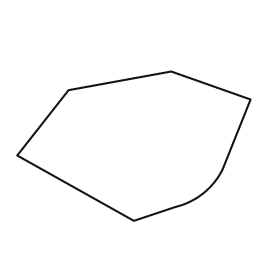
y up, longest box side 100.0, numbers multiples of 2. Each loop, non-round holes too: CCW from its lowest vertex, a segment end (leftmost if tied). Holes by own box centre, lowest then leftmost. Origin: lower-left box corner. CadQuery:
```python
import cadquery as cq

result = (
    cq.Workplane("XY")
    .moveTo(50.0, 0.0)
    .lineTo(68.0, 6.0)
    .threePointArc((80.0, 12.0), (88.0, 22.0))
    .lineTo(100.0, 52.0)
    .lineTo(66.0, 64.0)
    .lineTo(22.0, 56.0)
    .lineTo(0.0, 28.0)
    .close()
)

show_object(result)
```